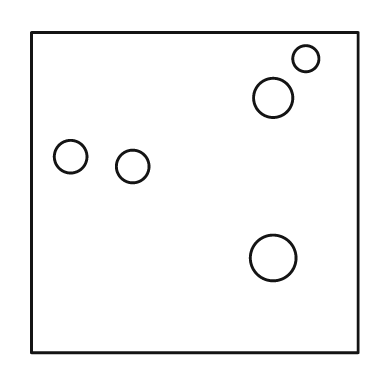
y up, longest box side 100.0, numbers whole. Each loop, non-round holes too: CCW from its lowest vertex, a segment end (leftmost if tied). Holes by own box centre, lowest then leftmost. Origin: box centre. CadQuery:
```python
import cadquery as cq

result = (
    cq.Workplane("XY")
    .moveTo(-50.0, -49.0)
    .lineTo(50.0, -49.0)
    .lineTo(50.0, 49.0)
    .lineTo(-50.0, 49.0)
    .close()
    .moveTo(24.0, -20.0)
    .circle(7.0)
    .moveTo(-19.0, 8.0)
    .circle(5.0)
    .moveTo(-38.0, 11.0)
    .circle(5.0)
    .moveTo(24.0, 29.0)
    .circle(6.0)
    .moveTo(34.0, 41.0)
    .circle(4.0)
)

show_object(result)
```